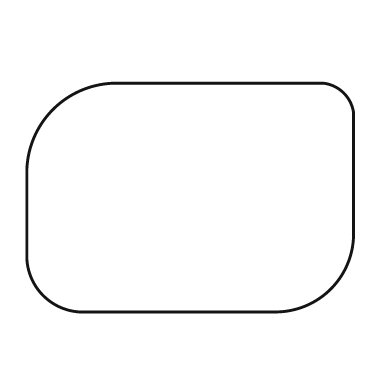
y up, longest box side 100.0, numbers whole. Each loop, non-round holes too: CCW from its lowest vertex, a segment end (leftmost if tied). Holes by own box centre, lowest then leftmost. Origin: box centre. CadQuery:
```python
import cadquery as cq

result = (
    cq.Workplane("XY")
    .moveTo(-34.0, -35.0)
    .lineTo(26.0, -35.0)
    .threePointArc((43.0, -28.0), (50.0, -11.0))
    .lineTo(50.0, 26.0)
    .threePointArc((47.0, 32.0), (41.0, 35.0))
    .lineTo(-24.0, 35.0)
    .threePointArc((-42.0, 27.0), (-50.0, 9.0))
    .lineTo(-50.0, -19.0)
    .threePointArc((-45.0, -30.0), (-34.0, -35.0))
    .close()
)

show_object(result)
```